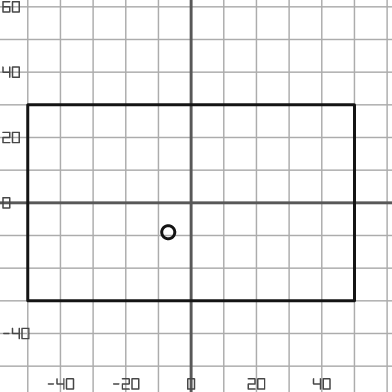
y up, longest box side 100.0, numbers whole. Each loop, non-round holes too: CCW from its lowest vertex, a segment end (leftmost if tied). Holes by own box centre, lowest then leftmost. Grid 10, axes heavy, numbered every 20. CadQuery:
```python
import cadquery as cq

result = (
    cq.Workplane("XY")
    .moveTo(-50.0, -30.0)
    .lineTo(50.0, -30.0)
    .lineTo(50.0, 30.0)
    .lineTo(-50.0, 30.0)
    .close()
    .moveTo(-7.0, -9.0)
    .circle(2.0)
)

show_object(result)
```